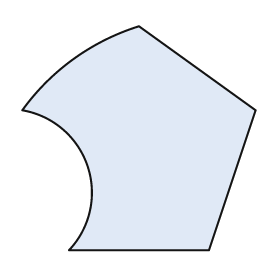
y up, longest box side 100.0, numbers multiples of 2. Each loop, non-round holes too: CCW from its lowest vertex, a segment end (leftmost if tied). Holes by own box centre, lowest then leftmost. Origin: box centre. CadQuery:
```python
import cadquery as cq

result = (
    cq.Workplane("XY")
    .moveTo(-30.0, -48.0)
    .lineTo(30.0, -48.0)
    .lineTo(50.0, 12.0)
    .lineTo(0.0, 48.0)
    .threePointArc((-28.0, 34.0), (-50.0, 12.0))
    .threePointArc((-22.0, -12.0), (-30.0, -48.0))
    .close()
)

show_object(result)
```